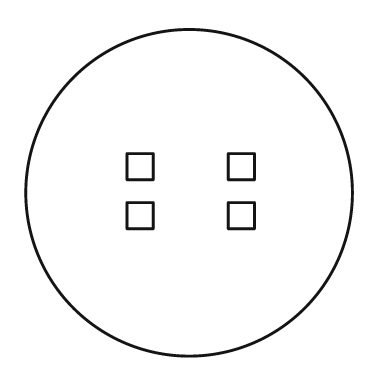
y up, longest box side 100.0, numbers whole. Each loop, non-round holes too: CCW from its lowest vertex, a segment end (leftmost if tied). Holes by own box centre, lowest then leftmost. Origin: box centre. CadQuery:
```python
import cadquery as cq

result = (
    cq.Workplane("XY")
    .moveTo(0.0, 0.0)
    .circle(50.0)
    .moveTo(-19.0, -11.0)
    .lineTo(-11.0, -11.0)
    .lineTo(-11.0, -3.0)
    .lineTo(-19.0, -3.0)
    .close()
    .moveTo(12.0, -11.0)
    .lineTo(20.0, -11.0)
    .lineTo(20.0, -3.0)
    .lineTo(12.0, -3.0)
    .close()
    .moveTo(-19.0, 4.0)
    .lineTo(-11.0, 4.0)
    .lineTo(-11.0, 12.0)
    .lineTo(-19.0, 12.0)
    .close()
    .moveTo(12.0, 4.0)
    .lineTo(20.0, 4.0)
    .lineTo(20.0, 12.0)
    .lineTo(12.0, 12.0)
    .close()
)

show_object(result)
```